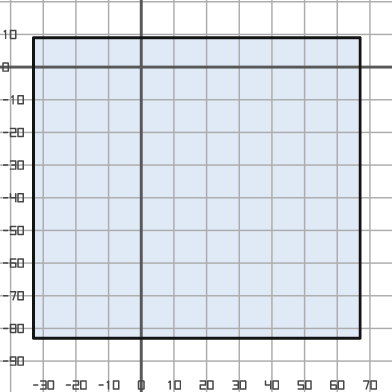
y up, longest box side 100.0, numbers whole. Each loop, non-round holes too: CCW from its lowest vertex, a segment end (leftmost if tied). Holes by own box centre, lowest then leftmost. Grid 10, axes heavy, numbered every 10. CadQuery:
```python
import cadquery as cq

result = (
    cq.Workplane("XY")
    .moveTo(-33.0, -83.0)
    .lineTo(67.0, -83.0)
    .lineTo(67.0, 9.0)
    .lineTo(-33.0, 9.0)
    .close()
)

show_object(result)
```